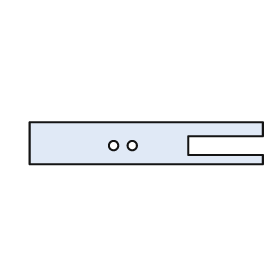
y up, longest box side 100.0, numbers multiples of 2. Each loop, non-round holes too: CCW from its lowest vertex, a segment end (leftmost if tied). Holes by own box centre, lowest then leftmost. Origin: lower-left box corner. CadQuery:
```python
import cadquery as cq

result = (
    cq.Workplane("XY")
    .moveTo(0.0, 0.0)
    .lineTo(100.0, 0.0)
    .lineTo(100.0, 4.0)
    .lineTo(68.0, 4.0)
    .lineTo(68.0, 12.0)
    .lineTo(100.0, 12.0)
    .lineTo(100.0, 18.0)
    .lineTo(0.0, 18.0)
    .close()
    .moveTo(36.0, 8.0)
    .circle(2.0)
    .moveTo(44.0, 8.0)
    .circle(2.0)
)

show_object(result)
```